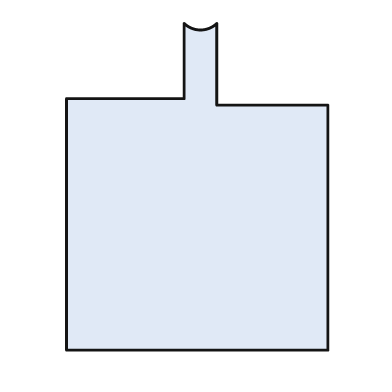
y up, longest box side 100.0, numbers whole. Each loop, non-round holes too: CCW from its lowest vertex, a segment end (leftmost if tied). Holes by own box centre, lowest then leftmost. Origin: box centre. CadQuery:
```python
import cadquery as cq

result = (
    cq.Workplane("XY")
    .moveTo(-40.0, -50.0)
    .lineTo(40.0, -50.0)
    .lineTo(40.0, 25.0)
    .lineTo(6.0, 25.0)
    .lineTo(6.0, 50.0)
    .threePointArc((1.0, 48.0), (-4.0, 50.0))
    .lineTo(-4.0, 27.0)
    .lineTo(-40.0, 27.0)
    .close()
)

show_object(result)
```